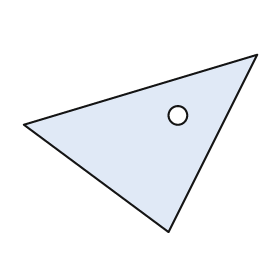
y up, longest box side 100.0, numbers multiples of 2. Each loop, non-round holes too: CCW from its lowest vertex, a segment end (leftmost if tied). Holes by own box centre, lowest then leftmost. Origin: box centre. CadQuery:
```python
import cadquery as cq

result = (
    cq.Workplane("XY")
    .moveTo(12.0, -38.0)
    .lineTo(50.0, 38.0)
    .lineTo(-50.0, 8.0)
    .close()
    .moveTo(16.0, 12.0)
    .circle(4.0)
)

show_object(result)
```